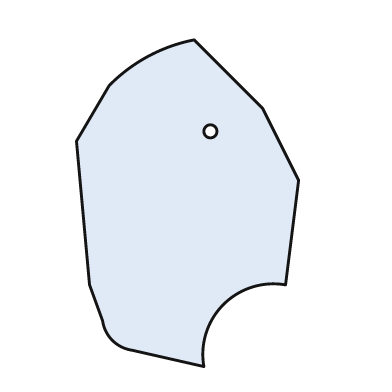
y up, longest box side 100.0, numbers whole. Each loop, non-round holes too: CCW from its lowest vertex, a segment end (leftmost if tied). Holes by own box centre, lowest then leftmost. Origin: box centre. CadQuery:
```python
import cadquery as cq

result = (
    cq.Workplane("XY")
    .moveTo(5.0, -50.0)
    .threePointArc((11.0, -31.0), (30.0, -25.0))
    .lineTo(34.0, 7.0)
    .lineTo(23.0, 29.0)
    .lineTo(2.0, 50.0)
    .threePointArc((-12.0, 45.0), (-24.0, 36.0))
    .lineTo(-34.0, 19.0)
    .lineTo(-30.0, -25.0)
    .lineTo(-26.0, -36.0)
    .threePointArc((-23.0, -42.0), (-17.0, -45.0))
    .close()
    .moveTo(7.0, 22.0)
    .circle(2.0)
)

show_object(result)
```